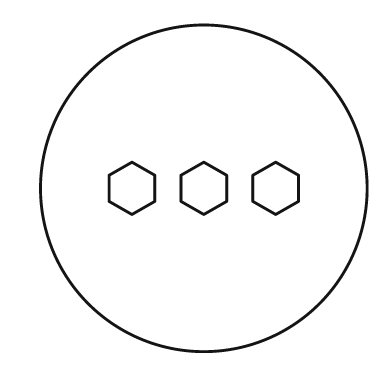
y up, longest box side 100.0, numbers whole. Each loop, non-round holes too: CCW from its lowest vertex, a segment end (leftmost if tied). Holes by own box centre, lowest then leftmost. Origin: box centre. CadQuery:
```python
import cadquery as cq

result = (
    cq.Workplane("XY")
    .moveTo(0.0, 0.0)
    .circle(50.0)
    .moveTo(-22.0, -8.0)
    .lineTo(-15.0, -4.0)
    .lineTo(-15.0, 4.0)
    .lineTo(-22.0, 8.0)
    .lineTo(-29.0, 4.0)
    .lineTo(-29.0, -4.0)
    .close()
    .moveTo(0.0, -8.0)
    .lineTo(7.0, -4.0)
    .lineTo(7.0, 4.0)
    .lineTo(0.0, 8.0)
    .lineTo(-7.0, 4.0)
    .lineTo(-7.0, -4.0)
    .close()
    .moveTo(22.0, -8.0)
    .lineTo(29.0, -4.0)
    .lineTo(29.0, 4.0)
    .lineTo(22.0, 8.0)
    .lineTo(15.0, 4.0)
    .lineTo(15.0, -4.0)
    .close()
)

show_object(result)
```